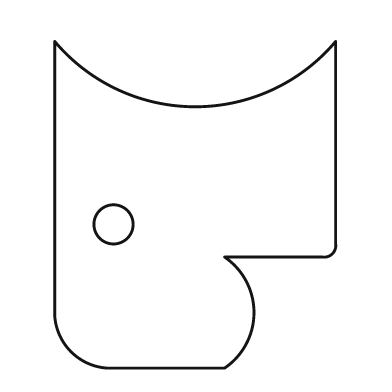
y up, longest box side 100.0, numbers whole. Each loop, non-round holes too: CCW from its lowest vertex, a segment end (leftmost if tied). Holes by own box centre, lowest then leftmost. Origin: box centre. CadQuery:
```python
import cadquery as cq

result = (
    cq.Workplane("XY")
    .moveTo(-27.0, -50.0)
    .lineTo(9.0, -50.0)
    .threePointArc((18.0, -33.0), (9.0, -16.0))
    .lineTo(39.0, -16.0)
    .threePointArc((42.0, -15.0), (43.0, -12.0))
    .lineTo(43.0, 50.0)
    .threePointArc((0.0, 30.0), (-43.0, 50.0))
    .lineTo(-43.0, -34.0)
    .threePointArc((-38.0, -45.0), (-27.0, -50.0))
    .close()
    .moveTo(-25.0, -6.0)
    .circle(6.0)
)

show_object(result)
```